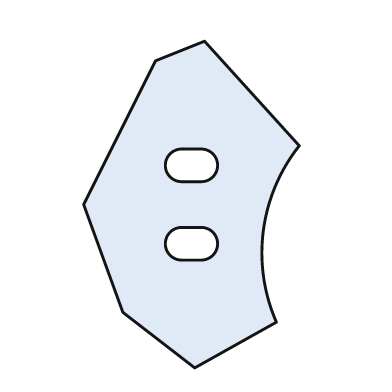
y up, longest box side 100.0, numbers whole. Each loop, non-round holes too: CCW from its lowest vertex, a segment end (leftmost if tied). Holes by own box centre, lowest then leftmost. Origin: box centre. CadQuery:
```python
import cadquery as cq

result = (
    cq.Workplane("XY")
    .moveTo(1.0, -50.0)
    .lineTo(26.0, -36.0)
    .threePointArc((22.0, -8.0), (33.0, 18.0))
    .lineTo(4.0, 50.0)
    .lineTo(-11.0, 44.0)
    .lineTo(-33.0, 0.0)
    .lineTo(-21.0, -33.0)
    .close()
    .moveTo(-3.0, -17.0)
    .lineTo(3.0, -17.0)
    .threePointArc((8.0, -12.0), (3.0, -7.0))
    .lineTo(-3.0, -7.0)
    .threePointArc((-8.0, -12.0), (-3.0, -17.0))
    .close()
    .moveTo(-3.0, 7.0)
    .lineTo(3.0, 7.0)
    .threePointArc((8.0, 12.0), (3.0, 17.0))
    .lineTo(-3.0, 17.0)
    .threePointArc((-8.0, 12.0), (-3.0, 7.0))
    .close()
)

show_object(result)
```